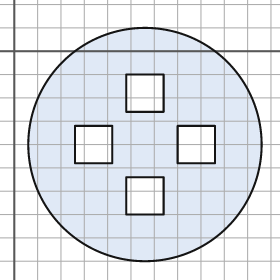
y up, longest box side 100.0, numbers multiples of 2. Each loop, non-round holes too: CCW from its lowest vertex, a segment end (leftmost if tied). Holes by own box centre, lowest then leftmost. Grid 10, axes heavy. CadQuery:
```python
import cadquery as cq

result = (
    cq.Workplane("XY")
    .moveTo(56.0, -40.0)
    .circle(50.0)
    .moveTo(48.0, -70.0)
    .lineTo(64.0, -70.0)
    .lineTo(64.0, -54.0)
    .lineTo(48.0, -54.0)
    .close()
    .moveTo(26.0, -48.0)
    .lineTo(42.0, -48.0)
    .lineTo(42.0, -32.0)
    .lineTo(26.0, -32.0)
    .close()
    .moveTo(70.0, -48.0)
    .lineTo(86.0, -48.0)
    .lineTo(86.0, -32.0)
    .lineTo(70.0, -32.0)
    .close()
    .moveTo(48.0, -26.0)
    .lineTo(64.0, -26.0)
    .lineTo(64.0, -10.0)
    .lineTo(48.0, -10.0)
    .close()
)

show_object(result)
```